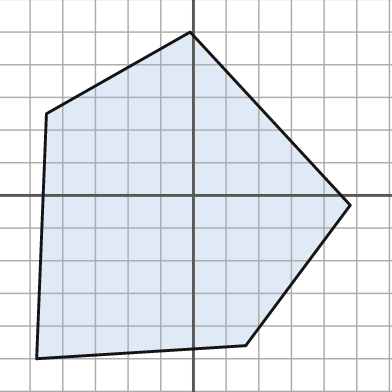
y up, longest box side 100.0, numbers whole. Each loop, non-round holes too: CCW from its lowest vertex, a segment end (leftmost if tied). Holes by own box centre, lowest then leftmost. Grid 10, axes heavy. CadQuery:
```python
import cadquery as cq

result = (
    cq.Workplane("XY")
    .moveTo(-48.0, -50.0)
    .lineTo(16.0, -46.0)
    .lineTo(48.0, -3.0)
    .lineTo(-1.0, 50.0)
    .lineTo(-45.0, 25.0)
    .close()
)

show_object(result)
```